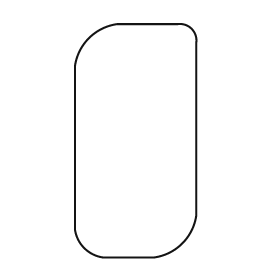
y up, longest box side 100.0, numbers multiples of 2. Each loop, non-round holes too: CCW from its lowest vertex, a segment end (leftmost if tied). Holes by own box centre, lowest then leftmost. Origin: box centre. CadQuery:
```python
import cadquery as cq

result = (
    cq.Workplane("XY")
    .moveTo(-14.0, -50.0)
    .lineTo(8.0, -50.0)
    .threePointArc((20.0, -44.0), (26.0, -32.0))
    .lineTo(26.0, 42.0)
    .threePointArc((24.0, 48.0), (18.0, 50.0))
    .lineTo(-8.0, 50.0)
    .threePointArc((-20.0, 44.0), (-26.0, 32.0))
    .lineTo(-26.0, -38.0)
    .threePointArc((-22.0, -46.0), (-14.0, -50.0))
    .close()
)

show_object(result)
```